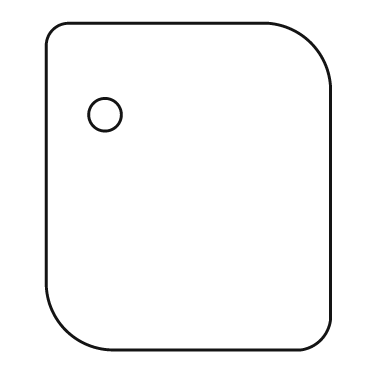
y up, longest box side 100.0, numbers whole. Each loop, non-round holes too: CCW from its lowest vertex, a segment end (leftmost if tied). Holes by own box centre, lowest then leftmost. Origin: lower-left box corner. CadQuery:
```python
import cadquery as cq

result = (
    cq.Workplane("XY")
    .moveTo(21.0, 0.0)
    .lineTo(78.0, 0.0)
    .threePointArc((84.0, 3.0), (87.0, 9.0))
    .lineTo(87.0, 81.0)
    .threePointArc((81.0, 94.0), (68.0, 100.0))
    .lineTo(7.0, 100.0)
    .threePointArc((2.0, 98.0), (0.0, 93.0))
    .lineTo(0.0, 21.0)
    .threePointArc((6.0, 6.0), (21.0, 0.0))
    .close()
    .moveTo(18.0, 72.0)
    .circle(5.0)
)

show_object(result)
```